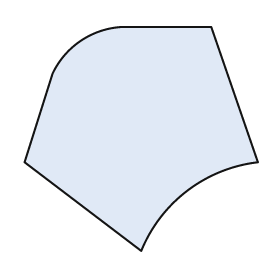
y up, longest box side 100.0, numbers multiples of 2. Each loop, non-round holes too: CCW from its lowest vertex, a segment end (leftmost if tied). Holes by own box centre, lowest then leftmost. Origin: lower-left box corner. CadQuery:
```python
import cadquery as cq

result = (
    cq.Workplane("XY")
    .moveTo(50.0, 0.0)
    .threePointArc((70.0, 26.0), (100.0, 38.0))
    .lineTo(80.0, 96.0)
    .lineTo(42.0, 96.0)
    .threePointArc((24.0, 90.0), (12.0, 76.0))
    .lineTo(0.0, 38.0)
    .close()
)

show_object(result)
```